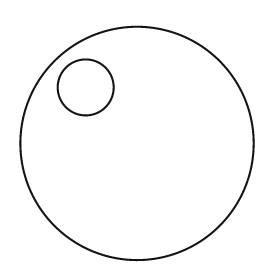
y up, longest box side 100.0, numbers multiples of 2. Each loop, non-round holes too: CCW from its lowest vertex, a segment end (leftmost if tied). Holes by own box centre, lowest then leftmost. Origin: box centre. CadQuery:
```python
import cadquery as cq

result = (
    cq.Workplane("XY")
    .moveTo(0.0, 0.0)
    .circle(50.0)
    .moveTo(-22.0, 24.0)
    .circle(12.0)
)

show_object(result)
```